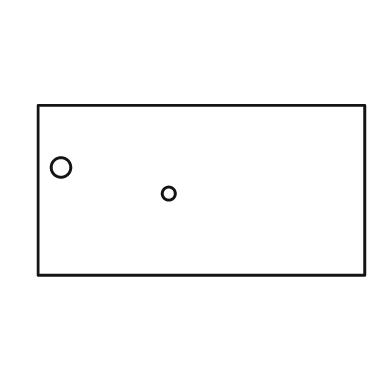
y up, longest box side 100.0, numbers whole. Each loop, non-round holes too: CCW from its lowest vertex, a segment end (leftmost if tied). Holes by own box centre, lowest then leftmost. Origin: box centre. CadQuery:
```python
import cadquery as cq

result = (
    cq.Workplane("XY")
    .moveTo(-50.0, -26.0)
    .lineTo(50.0, -26.0)
    .lineTo(50.0, 26.0)
    .lineTo(-50.0, 26.0)
    .close()
    .moveTo(-10.0, -1.0)
    .circle(2.0)
    .moveTo(-43.0, 7.0)
    .circle(3.0)
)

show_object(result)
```